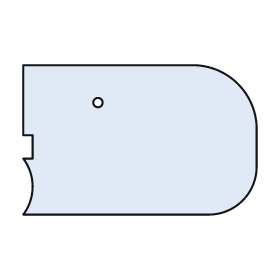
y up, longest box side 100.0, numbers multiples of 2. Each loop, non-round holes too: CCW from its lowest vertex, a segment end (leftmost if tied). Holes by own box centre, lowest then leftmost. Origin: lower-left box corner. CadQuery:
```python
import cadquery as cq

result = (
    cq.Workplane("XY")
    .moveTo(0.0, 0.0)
    .lineTo(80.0, 0.0)
    .threePointArc((94.0, 6.0), (100.0, 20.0))
    .lineTo(100.0, 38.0)
    .threePointArc((92.0, 56.0), (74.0, 64.0))
    .lineTo(0.0, 64.0)
    .lineTo(0.0, 34.0)
    .lineTo(4.0, 34.0)
    .lineTo(4.0, 24.0)
    .lineTo(0.0, 24.0)
    .threePointArc((4.0, 12.0), (0.0, 0.0))
    .close()
    .moveTo(32.0, 48.0)
    .circle(2.0)
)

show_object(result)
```